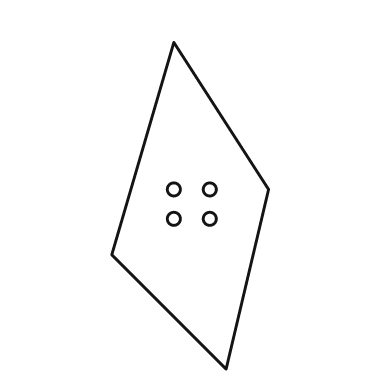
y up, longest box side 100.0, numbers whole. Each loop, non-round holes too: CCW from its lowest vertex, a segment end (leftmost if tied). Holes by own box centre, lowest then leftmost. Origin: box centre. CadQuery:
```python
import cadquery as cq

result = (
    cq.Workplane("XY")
    .moveTo(11.0, -50.0)
    .lineTo(24.0, 5.0)
    .lineTo(-5.0, 50.0)
    .lineTo(-24.0, -15.0)
    .close()
    .moveTo(-5.0, -4.0)
    .circle(2.0)
    .moveTo(6.0, -4.0)
    .circle(2.0)
    .moveTo(-5.0, 5.0)
    .circle(2.0)
    .moveTo(6.0, 5.0)
    .circle(2.0)
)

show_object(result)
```